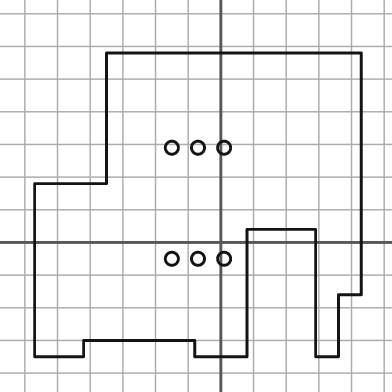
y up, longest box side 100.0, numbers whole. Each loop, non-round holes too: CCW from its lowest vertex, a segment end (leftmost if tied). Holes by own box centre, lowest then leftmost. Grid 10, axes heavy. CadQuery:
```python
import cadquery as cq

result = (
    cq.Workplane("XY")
    .moveTo(-57.0, -35.0)
    .lineTo(-42.0, -35.0)
    .lineTo(-42.0, -30.0)
    .lineTo(-8.0, -30.0)
    .lineTo(-8.0, -35.0)
    .lineTo(8.0, -35.0)
    .lineTo(8.0, 4.0)
    .lineTo(29.0, 4.0)
    .lineTo(29.0, -35.0)
    .lineTo(36.0, -35.0)
    .lineTo(36.0, -16.0)
    .lineTo(43.0, -16.0)
    .lineTo(43.0, 58.0)
    .lineTo(-35.0, 58.0)
    .lineTo(-35.0, 18.0)
    .lineTo(-57.0, 18.0)
    .close()
    .moveTo(-15.0, -5.0)
    .circle(2.0)
    .moveTo(-7.0, -5.0)
    .circle(2.0)
    .moveTo(1.0, -5.0)
    .circle(2.0)
    .moveTo(-15.0, 29.0)
    .circle(2.0)
    .moveTo(-7.0, 29.0)
    .circle(2.0)
    .moveTo(1.0, 29.0)
    .circle(2.0)
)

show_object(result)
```